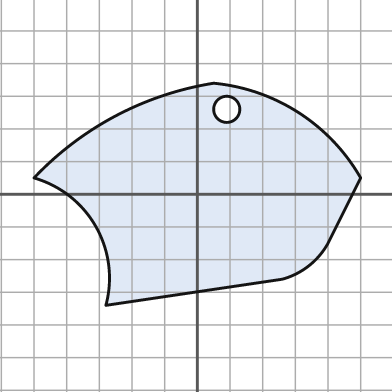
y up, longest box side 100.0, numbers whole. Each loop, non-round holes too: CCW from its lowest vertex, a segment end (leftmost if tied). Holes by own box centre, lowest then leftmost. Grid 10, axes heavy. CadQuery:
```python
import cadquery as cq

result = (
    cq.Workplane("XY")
    .moveTo(-28.0, -34.0)
    .lineTo(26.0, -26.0)
    .threePointArc((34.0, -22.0), (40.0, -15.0))
    .lineTo(50.0, 5.0)
    .threePointArc((31.0, 25.0), (5.0, 34.0))
    .threePointArc((-25.0, 24.0), (-50.0, 5.0))
    .threePointArc((-31.0, -10.0), (-28.0, -34.0))
    .close()
    .moveTo(9.0, 26.0)
    .circle(4.0)
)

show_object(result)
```